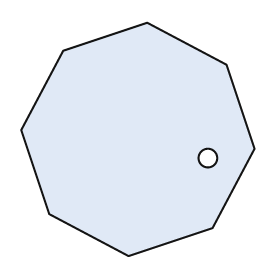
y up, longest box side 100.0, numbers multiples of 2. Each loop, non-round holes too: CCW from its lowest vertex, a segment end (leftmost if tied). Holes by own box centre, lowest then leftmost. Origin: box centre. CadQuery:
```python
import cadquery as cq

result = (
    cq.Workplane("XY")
    .moveTo(-4.0, -50.0)
    .lineTo(32.0, -38.0)
    .lineTo(50.0, -4.0)
    .lineTo(38.0, 32.0)
    .lineTo(4.0, 50.0)
    .lineTo(-32.0, 38.0)
    .lineTo(-50.0, 4.0)
    .lineTo(-38.0, -32.0)
    .close()
    .moveTo(30.0, -8.0)
    .circle(4.0)
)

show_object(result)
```